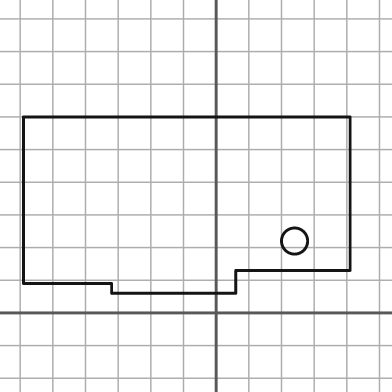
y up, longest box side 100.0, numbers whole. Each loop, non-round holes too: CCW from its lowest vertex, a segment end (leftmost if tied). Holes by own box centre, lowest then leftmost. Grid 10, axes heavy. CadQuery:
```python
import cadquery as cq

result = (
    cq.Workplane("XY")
    .moveTo(-32.0, 6.0)
    .lineTo(6.0, 6.0)
    .lineTo(6.0, 13.0)
    .lineTo(41.0, 13.0)
    .lineTo(41.0, 60.0)
    .lineTo(-59.0, 60.0)
    .lineTo(-59.0, 9.0)
    .lineTo(-32.0, 9.0)
    .close()
    .moveTo(24.0, 22.0)
    .circle(4.0)
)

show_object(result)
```